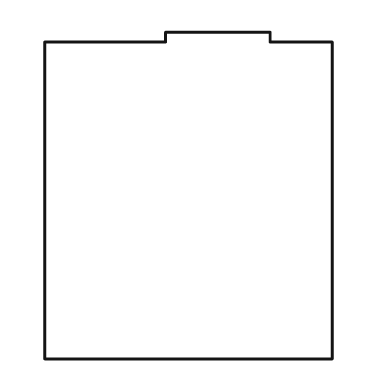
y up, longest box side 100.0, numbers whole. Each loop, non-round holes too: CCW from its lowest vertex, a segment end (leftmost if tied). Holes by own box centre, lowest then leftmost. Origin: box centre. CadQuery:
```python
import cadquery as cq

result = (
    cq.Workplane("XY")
    .moveTo(-44.0, -50.0)
    .lineTo(44.0, -50.0)
    .lineTo(44.0, 47.0)
    .lineTo(25.0, 47.0)
    .lineTo(25.0, 50.0)
    .lineTo(-7.0, 50.0)
    .lineTo(-7.0, 47.0)
    .lineTo(-44.0, 47.0)
    .close()
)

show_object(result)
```